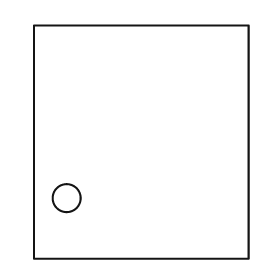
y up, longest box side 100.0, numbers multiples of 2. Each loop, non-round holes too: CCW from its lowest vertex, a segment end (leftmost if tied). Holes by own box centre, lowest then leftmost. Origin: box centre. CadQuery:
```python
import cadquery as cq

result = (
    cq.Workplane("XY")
    .moveTo(-46.0, -50.0)
    .lineTo(46.0, -50.0)
    .lineTo(46.0, 50.0)
    .lineTo(-46.0, 50.0)
    .close()
    .moveTo(-32.0, -24.0)
    .circle(6.0)
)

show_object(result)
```